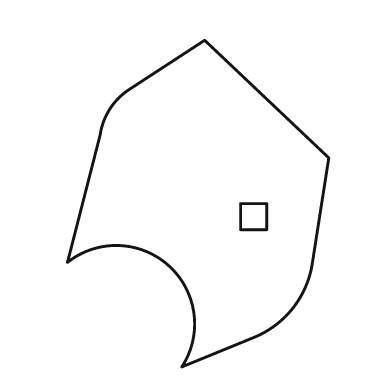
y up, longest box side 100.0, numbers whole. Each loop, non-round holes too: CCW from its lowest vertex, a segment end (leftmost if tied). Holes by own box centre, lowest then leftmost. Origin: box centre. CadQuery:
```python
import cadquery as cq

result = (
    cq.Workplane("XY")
    .moveTo(-5.0, -50.0)
    .lineTo(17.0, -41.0)
    .threePointArc((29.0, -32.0), (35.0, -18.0))
    .lineTo(40.0, 14.0)
    .lineTo(2.0, 50.0)
    .lineTo(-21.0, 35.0)
    .threePointArc((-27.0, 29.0), (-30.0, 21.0))
    .lineTo(-40.0, -18.0)
    .threePointArc((-9.0, -19.0), (-5.0, -50.0))
    .close()
    .moveTo(13.0, -8.0)
    .lineTo(21.0, -8.0)
    .lineTo(21.0, 0.0)
    .lineTo(13.0, 0.0)
    .close()
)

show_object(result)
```